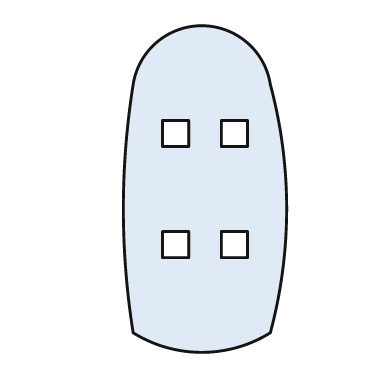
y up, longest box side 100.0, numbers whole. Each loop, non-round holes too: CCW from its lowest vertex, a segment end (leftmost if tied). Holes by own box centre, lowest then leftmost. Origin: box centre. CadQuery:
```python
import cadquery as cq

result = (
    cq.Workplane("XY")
    .moveTo(-22.0, -44.0)
    .threePointArc((-1.0, -50.0), (20.0, -44.0))
    .threePointArc((25.0, -6.0), (20.0, 32.0))
    .threePointArc((-1.0, 50.0), (-22.0, 32.0))
    .threePointArc((-25.0, -6.0), (-22.0, -44.0))
    .close()
    .moveTo(-13.0, -21.0)
    .lineTo(-5.0, -21.0)
    .lineTo(-5.0, -13.0)
    .lineTo(-13.0, -13.0)
    .close()
    .moveTo(5.0, -21.0)
    .lineTo(13.0, -21.0)
    .lineTo(13.0, -13.0)
    .lineTo(5.0, -13.0)
    .close()
    .moveTo(-13.0, 13.0)
    .lineTo(-5.0, 13.0)
    .lineTo(-5.0, 21.0)
    .lineTo(-13.0, 21.0)
    .close()
    .moveTo(5.0, 13.0)
    .lineTo(13.0, 13.0)
    .lineTo(13.0, 21.0)
    .lineTo(5.0, 21.0)
    .close()
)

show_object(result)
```